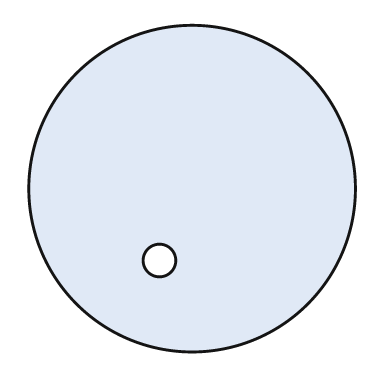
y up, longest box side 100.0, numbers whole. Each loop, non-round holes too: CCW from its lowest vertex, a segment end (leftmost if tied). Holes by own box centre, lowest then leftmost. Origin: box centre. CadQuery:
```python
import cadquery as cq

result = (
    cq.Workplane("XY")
    .moveTo(0.0, 0.0)
    .circle(50.0)
    .moveTo(-10.0, -22.0)
    .circle(5.0)
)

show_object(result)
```